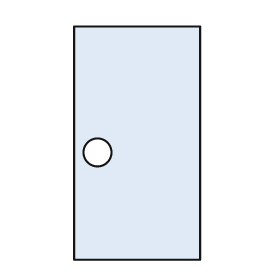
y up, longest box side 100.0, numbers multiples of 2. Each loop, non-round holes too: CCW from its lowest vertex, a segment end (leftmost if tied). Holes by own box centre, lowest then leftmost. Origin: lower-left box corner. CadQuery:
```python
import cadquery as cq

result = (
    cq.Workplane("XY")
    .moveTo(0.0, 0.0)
    .lineTo(54.0, 0.0)
    .lineTo(54.0, 100.0)
    .lineTo(0.0, 100.0)
    .close()
    .moveTo(10.0, 46.0)
    .circle(6.0)
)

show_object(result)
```